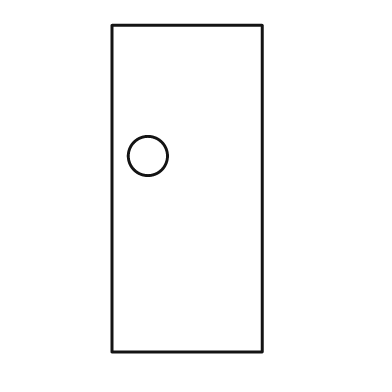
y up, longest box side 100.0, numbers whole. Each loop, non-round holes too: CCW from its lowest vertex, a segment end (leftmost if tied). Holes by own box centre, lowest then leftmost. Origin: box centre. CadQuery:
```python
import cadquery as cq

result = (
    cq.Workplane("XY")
    .moveTo(-23.0, -50.0)
    .lineTo(23.0, -50.0)
    .lineTo(23.0, 50.0)
    .lineTo(-23.0, 50.0)
    .close()
    .moveTo(-12.0, 10.0)
    .circle(6.0)
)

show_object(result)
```